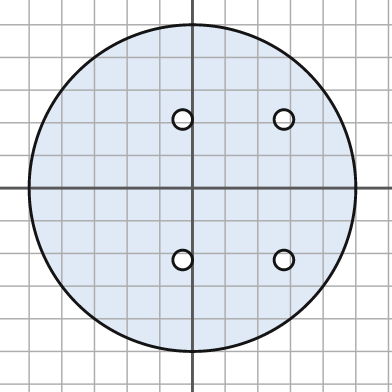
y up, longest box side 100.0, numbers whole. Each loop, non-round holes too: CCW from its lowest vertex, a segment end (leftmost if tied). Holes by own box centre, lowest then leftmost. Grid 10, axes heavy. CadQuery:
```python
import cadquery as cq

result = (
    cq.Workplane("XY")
    .moveTo(0.0, 0.0)
    .circle(50.0)
    .moveTo(-3.0, -22.0)
    .circle(3.0)
    .moveTo(28.0, -22.0)
    .circle(3.0)
    .moveTo(-3.0, 21.0)
    .circle(3.0)
    .moveTo(28.0, 21.0)
    .circle(3.0)
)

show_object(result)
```